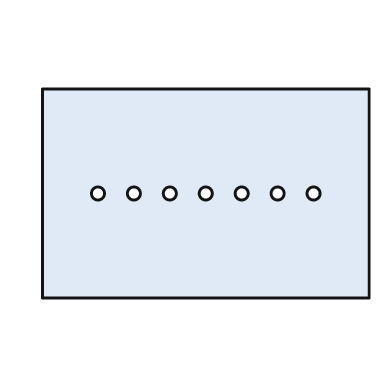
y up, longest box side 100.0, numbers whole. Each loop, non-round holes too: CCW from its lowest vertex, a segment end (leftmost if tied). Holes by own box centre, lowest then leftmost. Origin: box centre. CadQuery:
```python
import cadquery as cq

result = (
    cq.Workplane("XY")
    .moveTo(-50.0, -32.0)
    .lineTo(50.0, -32.0)
    .lineTo(50.0, 32.0)
    .lineTo(-50.0, 32.0)
    .close()
    .moveTo(-33.0, 0.0)
    .circle(2.0)
    .moveTo(-22.0, 0.0)
    .circle(2.0)
    .moveTo(-11.0, 0.0)
    .circle(2.0)
    .moveTo(0.0, 0.0)
    .circle(2.0)
    .moveTo(11.0, 0.0)
    .circle(2.0)
    .moveTo(22.0, 0.0)
    .circle(2.0)
    .moveTo(33.0, 0.0)
    .circle(2.0)
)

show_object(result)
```